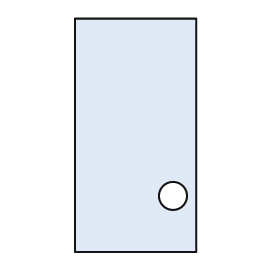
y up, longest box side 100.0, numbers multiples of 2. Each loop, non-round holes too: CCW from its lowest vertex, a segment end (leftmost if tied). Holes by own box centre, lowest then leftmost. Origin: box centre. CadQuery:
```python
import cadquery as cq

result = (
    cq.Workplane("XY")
    .moveTo(-26.0, -50.0)
    .lineTo(26.0, -50.0)
    .lineTo(26.0, 50.0)
    .lineTo(-26.0, 50.0)
    .close()
    .moveTo(16.0, -26.0)
    .circle(6.0)
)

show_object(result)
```